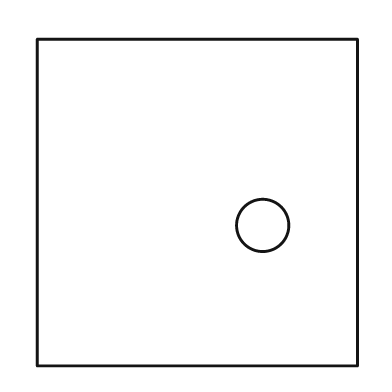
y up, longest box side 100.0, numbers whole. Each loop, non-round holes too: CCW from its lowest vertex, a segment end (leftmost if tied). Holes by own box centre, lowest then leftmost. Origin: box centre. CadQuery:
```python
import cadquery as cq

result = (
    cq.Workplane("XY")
    .moveTo(-49.0, -50.0)
    .lineTo(49.0, -50.0)
    .lineTo(49.0, 50.0)
    .lineTo(-49.0, 50.0)
    .close()
    .moveTo(20.0, -7.0)
    .circle(8.0)
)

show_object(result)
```